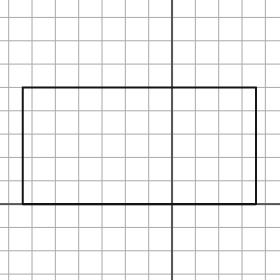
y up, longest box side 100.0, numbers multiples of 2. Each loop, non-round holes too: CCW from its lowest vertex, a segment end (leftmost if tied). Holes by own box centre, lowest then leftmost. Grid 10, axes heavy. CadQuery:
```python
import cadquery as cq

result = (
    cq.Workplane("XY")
    .moveTo(-64.0, 0.0)
    .lineTo(36.0, 0.0)
    .lineTo(36.0, 50.0)
    .lineTo(-64.0, 50.0)
    .close()
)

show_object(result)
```